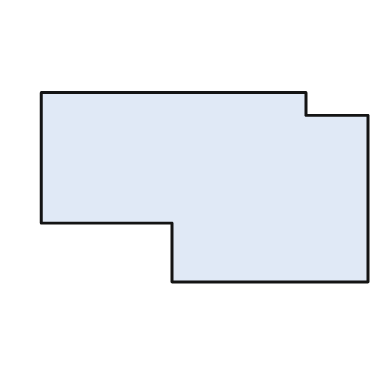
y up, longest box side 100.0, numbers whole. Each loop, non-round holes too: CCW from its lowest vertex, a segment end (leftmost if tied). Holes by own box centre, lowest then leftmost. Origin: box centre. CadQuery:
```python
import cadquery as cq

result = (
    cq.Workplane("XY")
    .moveTo(-10.0, -29.0)
    .lineTo(50.0, -29.0)
    .lineTo(50.0, 22.0)
    .lineTo(31.0, 22.0)
    .lineTo(31.0, 29.0)
    .lineTo(-50.0, 29.0)
    .lineTo(-50.0, -11.0)
    .lineTo(-10.0, -11.0)
    .close()
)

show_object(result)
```